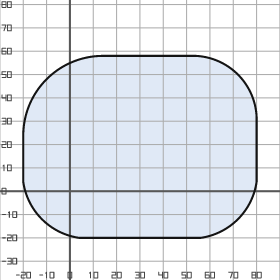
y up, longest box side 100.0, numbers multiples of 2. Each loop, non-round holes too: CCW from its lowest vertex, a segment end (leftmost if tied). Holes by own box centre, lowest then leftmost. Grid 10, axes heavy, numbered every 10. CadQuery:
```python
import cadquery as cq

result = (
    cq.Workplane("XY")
    .moveTo(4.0, -20.0)
    .lineTo(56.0, -20.0)
    .threePointArc((72.0, -12.0), (80.0, 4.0))
    .lineTo(80.0, 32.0)
    .threePointArc((72.0, 50.0), (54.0, 58.0))
    .lineTo(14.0, 58.0)
    .threePointArc((-10.0, 48.0), (-20.0, 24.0))
    .lineTo(-20.0, 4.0)
    .threePointArc((-12.0, -12.0), (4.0, -20.0))
    .close()
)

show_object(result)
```